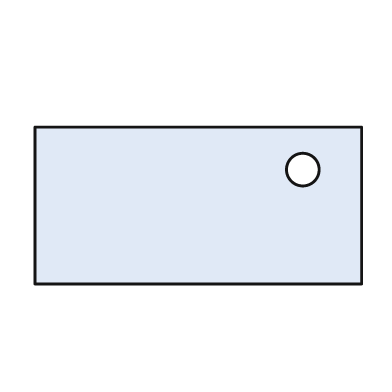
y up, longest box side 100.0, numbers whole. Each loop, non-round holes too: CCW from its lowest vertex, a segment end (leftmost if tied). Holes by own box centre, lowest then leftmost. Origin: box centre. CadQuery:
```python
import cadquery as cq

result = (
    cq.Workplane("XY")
    .moveTo(-50.0, -24.0)
    .lineTo(50.0, -24.0)
    .lineTo(50.0, 24.0)
    .lineTo(-50.0, 24.0)
    .close()
    .moveTo(32.0, 11.0)
    .circle(5.0)
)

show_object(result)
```